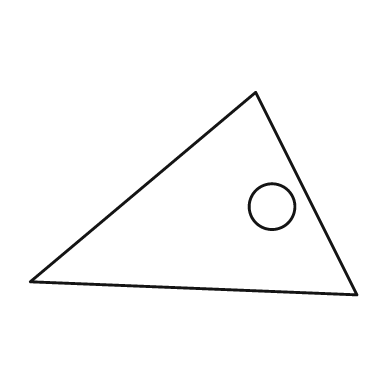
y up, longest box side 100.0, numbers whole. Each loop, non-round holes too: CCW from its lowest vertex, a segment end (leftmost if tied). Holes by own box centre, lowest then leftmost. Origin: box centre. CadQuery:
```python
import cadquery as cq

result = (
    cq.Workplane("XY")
    .moveTo(50.0, -31.0)
    .lineTo(19.0, 31.0)
    .lineTo(-50.0, -27.0)
    .close()
    .moveTo(24.0, -4.0)
    .circle(7.0)
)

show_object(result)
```